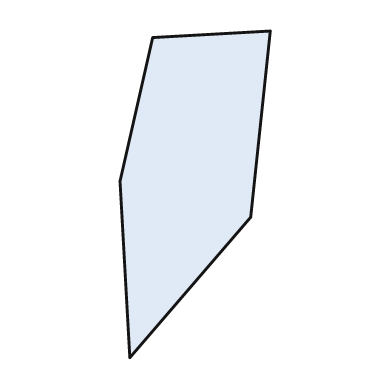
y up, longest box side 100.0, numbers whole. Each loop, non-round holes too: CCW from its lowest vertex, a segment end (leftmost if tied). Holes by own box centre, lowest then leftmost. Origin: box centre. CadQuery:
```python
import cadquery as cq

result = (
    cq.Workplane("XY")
    .moveTo(-20.0, -50.0)
    .lineTo(17.0, -7.0)
    .lineTo(23.0, 50.0)
    .lineTo(-13.0, 48.0)
    .lineTo(-23.0, 4.0)
    .close()
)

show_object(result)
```